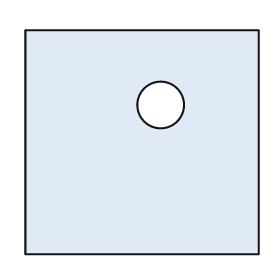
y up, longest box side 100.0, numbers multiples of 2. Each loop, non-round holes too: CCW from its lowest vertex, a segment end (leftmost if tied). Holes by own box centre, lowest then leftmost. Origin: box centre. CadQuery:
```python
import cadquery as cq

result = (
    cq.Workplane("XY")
    .moveTo(-50.0, -48.0)
    .lineTo(50.0, -48.0)
    .lineTo(50.0, 48.0)
    .lineTo(-50.0, 48.0)
    .close()
    .moveTo(8.0, 16.0)
    .circle(10.0)
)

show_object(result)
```